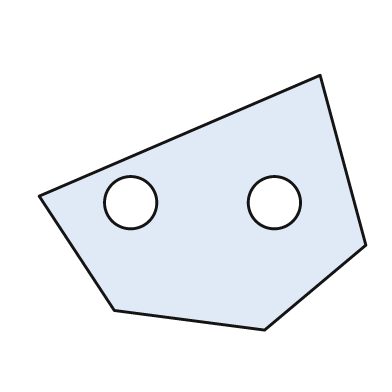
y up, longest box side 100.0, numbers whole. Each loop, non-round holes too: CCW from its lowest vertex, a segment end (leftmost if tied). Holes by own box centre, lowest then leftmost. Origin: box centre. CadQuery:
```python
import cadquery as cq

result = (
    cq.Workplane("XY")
    .moveTo(19.0, -39.0)
    .lineTo(50.0, -13.0)
    .lineTo(36.0, 39.0)
    .lineTo(-50.0, 2.0)
    .lineTo(-27.0, -33.0)
    .close()
    .moveTo(-22.0, 0.0)
    .circle(8.0)
    .moveTo(22.0, 0.0)
    .circle(8.0)
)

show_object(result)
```